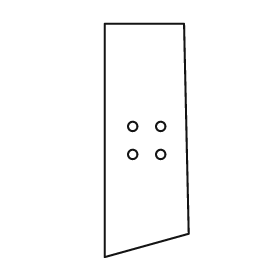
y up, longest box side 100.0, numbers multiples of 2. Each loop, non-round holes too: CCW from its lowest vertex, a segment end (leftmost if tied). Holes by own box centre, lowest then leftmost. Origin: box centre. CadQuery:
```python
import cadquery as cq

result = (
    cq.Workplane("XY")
    .moveTo(-18.0, -50.0)
    .lineTo(18.0, -40.0)
    .lineTo(16.0, 50.0)
    .lineTo(-18.0, 50.0)
    .close()
    .moveTo(-6.0, -6.0)
    .circle(2.0)
    .moveTo(6.0, -6.0)
    .circle(2.0)
    .moveTo(-6.0, 6.0)
    .circle(2.0)
    .moveTo(6.0, 6.0)
    .circle(2.0)
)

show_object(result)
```